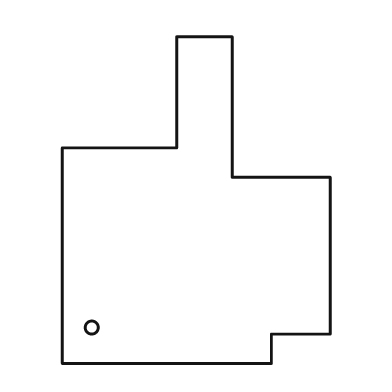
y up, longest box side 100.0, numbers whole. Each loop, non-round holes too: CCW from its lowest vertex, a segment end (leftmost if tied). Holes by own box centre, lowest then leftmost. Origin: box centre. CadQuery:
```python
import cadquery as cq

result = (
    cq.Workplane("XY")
    .moveTo(-41.0, -50.0)
    .lineTo(23.0, -50.0)
    .lineTo(23.0, -41.0)
    .lineTo(41.0, -41.0)
    .lineTo(41.0, 7.0)
    .lineTo(11.0, 7.0)
    .lineTo(11.0, 50.0)
    .lineTo(-6.0, 50.0)
    .lineTo(-6.0, 16.0)
    .lineTo(-41.0, 16.0)
    .close()
    .moveTo(-32.0, -39.0)
    .circle(2.0)
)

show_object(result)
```